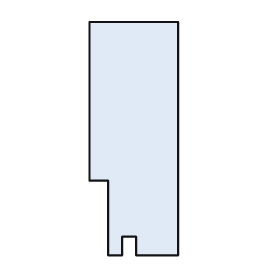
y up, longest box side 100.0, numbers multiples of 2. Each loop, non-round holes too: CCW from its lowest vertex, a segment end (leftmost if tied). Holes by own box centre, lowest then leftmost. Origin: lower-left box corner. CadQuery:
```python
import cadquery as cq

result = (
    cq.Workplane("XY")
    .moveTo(8.0, 0.0)
    .lineTo(14.0, 0.0)
    .lineTo(14.0, 8.0)
    .lineTo(20.0, 8.0)
    .lineTo(20.0, 0.0)
    .lineTo(38.0, 0.0)
    .lineTo(38.0, 100.0)
    .lineTo(0.0, 100.0)
    .lineTo(0.0, 32.0)
    .lineTo(8.0, 32.0)
    .close()
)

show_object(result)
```